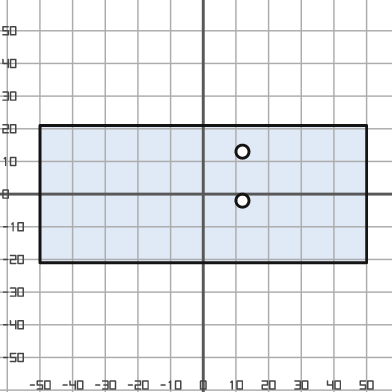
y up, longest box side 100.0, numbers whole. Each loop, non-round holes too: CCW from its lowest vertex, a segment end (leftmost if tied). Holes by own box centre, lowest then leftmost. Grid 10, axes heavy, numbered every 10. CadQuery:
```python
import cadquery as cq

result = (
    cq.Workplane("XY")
    .moveTo(-50.0, -21.0)
    .lineTo(50.0, -21.0)
    .lineTo(50.0, 21.0)
    .lineTo(-50.0, 21.0)
    .close()
    .moveTo(12.0, -2.0)
    .circle(2.0)
    .moveTo(12.0, 13.0)
    .circle(2.0)
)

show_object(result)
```